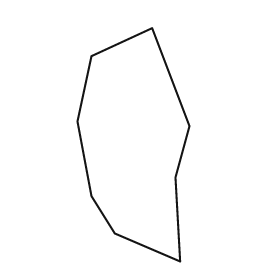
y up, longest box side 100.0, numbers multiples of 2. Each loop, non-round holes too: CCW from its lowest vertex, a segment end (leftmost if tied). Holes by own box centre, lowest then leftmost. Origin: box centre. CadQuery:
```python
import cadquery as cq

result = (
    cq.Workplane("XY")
    .moveTo(20.0, -50.0)
    .lineTo(18.0, -14.0)
    .lineTo(24.0, 8.0)
    .lineTo(8.0, 50.0)
    .lineTo(-18.0, 38.0)
    .lineTo(-24.0, 10.0)
    .lineTo(-18.0, -22.0)
    .lineTo(-8.0, -38.0)
    .close()
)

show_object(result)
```